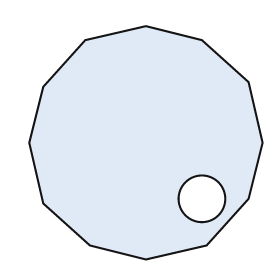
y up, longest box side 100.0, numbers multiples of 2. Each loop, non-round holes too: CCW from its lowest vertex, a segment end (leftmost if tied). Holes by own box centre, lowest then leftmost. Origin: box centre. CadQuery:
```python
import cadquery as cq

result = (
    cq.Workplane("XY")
    .moveTo(0.0, -50.0)
    .lineTo(26.0, -44.0)
    .lineTo(44.0, -24.0)
    .lineTo(50.0, 0.0)
    .lineTo(44.0, 26.0)
    .lineTo(24.0, 44.0)
    .lineTo(0.0, 50.0)
    .lineTo(-26.0, 44.0)
    .lineTo(-44.0, 24.0)
    .lineTo(-50.0, 0.0)
    .lineTo(-44.0, -26.0)
    .lineTo(-24.0, -44.0)
    .close()
    .moveTo(24.0, -24.0)
    .circle(10.0)
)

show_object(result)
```